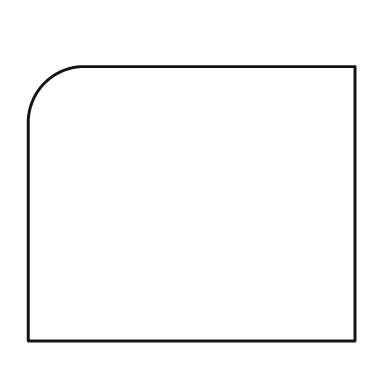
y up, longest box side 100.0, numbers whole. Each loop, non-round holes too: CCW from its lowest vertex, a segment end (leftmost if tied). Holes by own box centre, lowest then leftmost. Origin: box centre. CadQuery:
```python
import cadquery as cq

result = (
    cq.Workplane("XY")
    .moveTo(-50.0, -42.0)
    .lineTo(50.0, -42.0)
    .lineTo(50.0, 42.0)
    .lineTo(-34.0, 42.0)
    .threePointArc((-45.0, 37.0), (-50.0, 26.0))
    .close()
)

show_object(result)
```